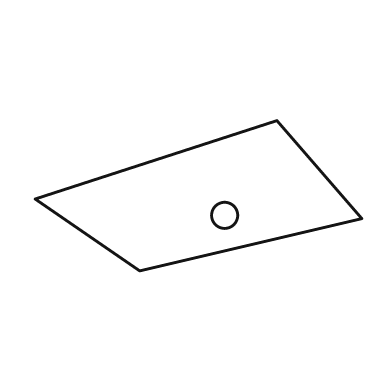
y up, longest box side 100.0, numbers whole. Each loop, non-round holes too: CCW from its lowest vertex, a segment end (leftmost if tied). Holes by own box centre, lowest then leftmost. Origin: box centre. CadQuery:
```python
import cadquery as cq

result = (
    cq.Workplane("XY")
    .moveTo(-18.0, -23.0)
    .lineTo(50.0, -7.0)
    .lineTo(24.0, 23.0)
    .lineTo(-50.0, -1.0)
    .close()
    .moveTo(8.0, -6.0)
    .circle(4.0)
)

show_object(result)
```